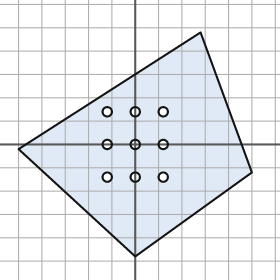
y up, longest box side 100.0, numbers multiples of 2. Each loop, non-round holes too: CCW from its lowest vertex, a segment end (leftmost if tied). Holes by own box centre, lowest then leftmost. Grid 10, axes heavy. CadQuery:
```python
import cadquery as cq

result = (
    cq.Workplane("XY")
    .moveTo(0.0, -48.0)
    .lineTo(50.0, -12.0)
    .lineTo(28.0, 48.0)
    .lineTo(-50.0, -2.0)
    .close()
    .moveTo(-12.0, -14.0)
    .circle(2.0)
    .moveTo(0.0, -14.0)
    .circle(2.0)
    .moveTo(12.0, -14.0)
    .circle(2.0)
    .moveTo(-12.0, 0.0)
    .circle(2.0)
    .moveTo(0.0, 0.0)
    .circle(2.0)
    .moveTo(12.0, 0.0)
    .circle(2.0)
    .moveTo(-12.0, 14.0)
    .circle(2.0)
    .moveTo(0.0, 14.0)
    .circle(2.0)
    .moveTo(12.0, 14.0)
    .circle(2.0)
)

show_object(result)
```